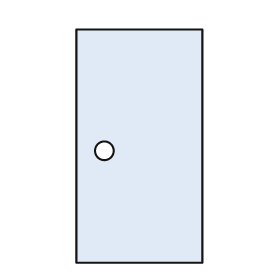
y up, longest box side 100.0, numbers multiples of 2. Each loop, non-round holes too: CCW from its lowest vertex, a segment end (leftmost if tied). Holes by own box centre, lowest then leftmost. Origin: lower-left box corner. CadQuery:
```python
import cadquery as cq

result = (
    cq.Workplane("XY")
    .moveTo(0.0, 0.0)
    .lineTo(54.0, 0.0)
    .lineTo(54.0, 100.0)
    .lineTo(0.0, 100.0)
    .close()
    .moveTo(12.0, 48.0)
    .circle(4.0)
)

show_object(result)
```